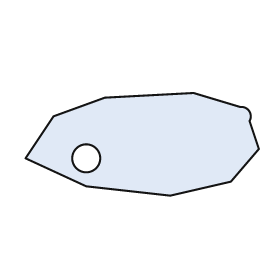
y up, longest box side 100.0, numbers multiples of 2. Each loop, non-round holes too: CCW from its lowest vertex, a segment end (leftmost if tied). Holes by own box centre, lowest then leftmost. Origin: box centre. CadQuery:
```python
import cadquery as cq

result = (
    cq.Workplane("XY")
    .moveTo(12.0, -22.0)
    .lineTo(38.0, -16.0)
    .lineTo(50.0, -2.0)
    .lineTo(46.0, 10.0)
    .threePointArc((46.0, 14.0), (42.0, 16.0))
    .lineTo(22.0, 22.0)
    .lineTo(-16.0, 20.0)
    .lineTo(-38.0, 12.0)
    .lineTo(-50.0, -6.0)
    .lineTo(-24.0, -18.0)
    .close()
    .moveTo(-24.0, -6.0)
    .circle(6.0)
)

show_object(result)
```